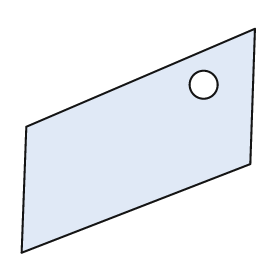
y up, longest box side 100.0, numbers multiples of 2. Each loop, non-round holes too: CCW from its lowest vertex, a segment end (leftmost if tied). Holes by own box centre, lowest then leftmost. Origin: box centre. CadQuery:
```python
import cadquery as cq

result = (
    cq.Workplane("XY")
    .moveTo(-50.0, -48.0)
    .lineTo(48.0, -10.0)
    .lineTo(50.0, 48.0)
    .lineTo(-48.0, 6.0)
    .close()
    .moveTo(28.0, 24.0)
    .circle(6.0)
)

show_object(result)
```